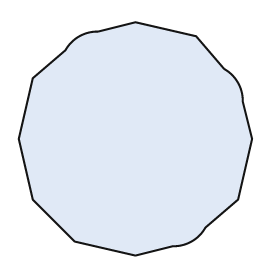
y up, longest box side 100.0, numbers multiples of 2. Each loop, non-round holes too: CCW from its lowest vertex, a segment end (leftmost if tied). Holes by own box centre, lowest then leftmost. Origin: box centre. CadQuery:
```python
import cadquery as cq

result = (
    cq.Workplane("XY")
    .moveTo(0.0, -50.0)
    .lineTo(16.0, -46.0)
    .threePointArc((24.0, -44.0), (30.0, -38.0))
    .lineTo(44.0, -26.0)
    .lineTo(50.0, 0.0)
    .lineTo(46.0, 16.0)
    .threePointArc((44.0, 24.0), (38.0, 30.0))
    .lineTo(26.0, 44.0)
    .lineTo(0.0, 50.0)
    .lineTo(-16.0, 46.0)
    .threePointArc((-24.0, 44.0), (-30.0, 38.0))
    .lineTo(-44.0, 26.0)
    .lineTo(-50.0, 0.0)
    .lineTo(-44.0, -26.0)
    .lineTo(-26.0, -44.0)
    .close()
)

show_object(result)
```